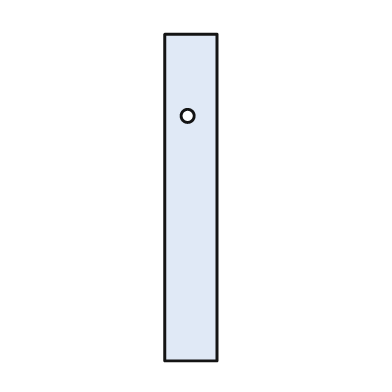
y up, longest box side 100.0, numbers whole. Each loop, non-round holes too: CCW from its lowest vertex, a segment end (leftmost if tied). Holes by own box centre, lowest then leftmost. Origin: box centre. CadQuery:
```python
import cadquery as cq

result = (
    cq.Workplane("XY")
    .moveTo(-8.0, -50.0)
    .lineTo(8.0, -50.0)
    .lineTo(8.0, 50.0)
    .lineTo(-8.0, 50.0)
    .close()
    .moveTo(-1.0, 25.0)
    .circle(2.0)
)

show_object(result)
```